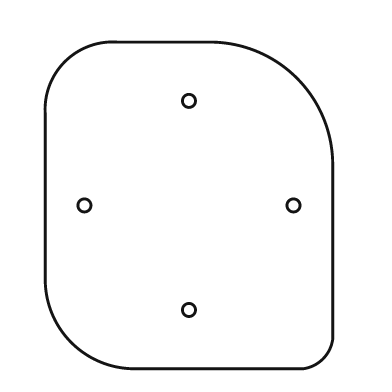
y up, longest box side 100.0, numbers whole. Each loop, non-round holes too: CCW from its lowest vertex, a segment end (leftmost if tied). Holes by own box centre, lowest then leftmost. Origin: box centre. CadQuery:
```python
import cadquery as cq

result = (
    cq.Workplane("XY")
    .moveTo(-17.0, -50.0)
    .lineTo(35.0, -50.0)
    .threePointArc((41.0, -47.0), (44.0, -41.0))
    .lineTo(44.0, 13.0)
    .threePointArc((33.0, 39.0), (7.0, 50.0))
    .lineTo(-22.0, 50.0)
    .threePointArc((-38.0, 44.0), (-44.0, 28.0))
    .lineTo(-44.0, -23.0)
    .threePointArc((-36.0, -42.0), (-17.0, -50.0))
    .close()
    .moveTo(0.0, -32.0)
    .circle(2.0)
    .moveTo(-32.0, 0.0)
    .circle(2.0)
    .moveTo(32.0, 0.0)
    .circle(2.0)
    .moveTo(0.0, 32.0)
    .circle(2.0)
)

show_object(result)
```